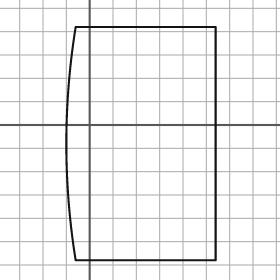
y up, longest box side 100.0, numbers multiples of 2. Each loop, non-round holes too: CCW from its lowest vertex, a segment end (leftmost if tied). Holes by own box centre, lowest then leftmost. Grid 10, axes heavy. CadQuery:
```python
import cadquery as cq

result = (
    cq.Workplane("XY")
    .moveTo(-6.0, -58.0)
    .lineTo(54.0, -58.0)
    .lineTo(54.0, 42.0)
    .lineTo(-6.0, 42.0)
    .threePointArc((-10.0, -8.0), (-6.0, -58.0))
    .close()
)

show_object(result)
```